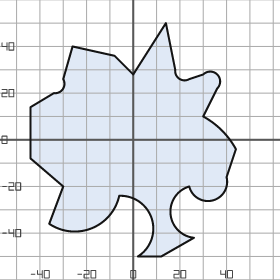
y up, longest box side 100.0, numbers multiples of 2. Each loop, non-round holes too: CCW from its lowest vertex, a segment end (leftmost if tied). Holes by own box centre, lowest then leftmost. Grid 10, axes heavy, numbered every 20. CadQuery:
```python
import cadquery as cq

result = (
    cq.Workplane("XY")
    .moveTo(2.0, -50.0)
    .lineTo(12.0, -50.0)
    .lineTo(26.0, -42.0)
    .threePointArc((16.0, -32.0), (24.0, -20.0))
    .threePointArc((34.0, -26.0), (40.0, -16.0))
    .lineTo(44.0, -4.0)
    .threePointArc((38.0, 4.0), (30.0, 10.0))
    .lineTo(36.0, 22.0)
    .threePointArc((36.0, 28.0), (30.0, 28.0))
    .lineTo(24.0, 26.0)
    .threePointArc((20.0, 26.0), (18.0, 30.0))
    .lineTo(14.0, 50.0)
    .lineTo(0.0, 28.0)
    .lineTo(-8.0, 36.0)
    .lineTo(-26.0, 40.0)
    .lineTo(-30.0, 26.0)
    .threePointArc((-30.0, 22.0), (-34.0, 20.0))
    .lineTo(-44.0, 14.0)
    .lineTo(-44.0, -8.0)
    .lineTo(-30.0, -20.0)
    .lineTo(-36.0, -36.0)
    .threePointArc((-18.0, -38.0), (-6.0, -24.0))
    .threePointArc((8.0, -34.0), (2.0, -50.0))
    .close()
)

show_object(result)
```